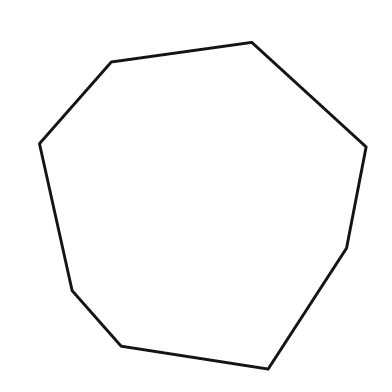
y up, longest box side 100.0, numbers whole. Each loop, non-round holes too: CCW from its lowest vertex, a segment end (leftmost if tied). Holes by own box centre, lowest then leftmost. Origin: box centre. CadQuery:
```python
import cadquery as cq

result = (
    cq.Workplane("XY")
    .moveTo(20.0, -50.0)
    .lineTo(44.0, -13.0)
    .lineTo(50.0, 18.0)
    .lineTo(15.0, 50.0)
    .lineTo(-28.0, 44.0)
    .lineTo(-50.0, 19.0)
    .lineTo(-40.0, -26.0)
    .lineTo(-25.0, -43.0)
    .close()
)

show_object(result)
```